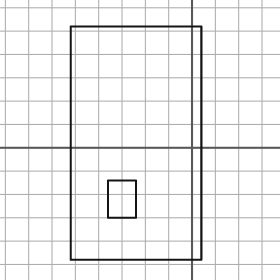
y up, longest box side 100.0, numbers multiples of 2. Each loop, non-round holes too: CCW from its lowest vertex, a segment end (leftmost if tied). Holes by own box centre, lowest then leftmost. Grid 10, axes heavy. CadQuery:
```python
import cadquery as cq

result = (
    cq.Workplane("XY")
    .moveTo(-52.0, -48.0)
    .lineTo(4.0, -48.0)
    .lineTo(4.0, 52.0)
    .lineTo(-52.0, 52.0)
    .close()
    .moveTo(-36.0, -30.0)
    .lineTo(-24.0, -30.0)
    .lineTo(-24.0, -14.0)
    .lineTo(-36.0, -14.0)
    .close()
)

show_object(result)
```